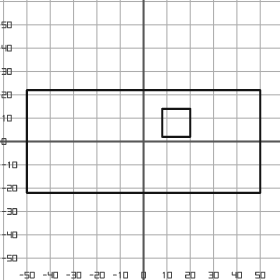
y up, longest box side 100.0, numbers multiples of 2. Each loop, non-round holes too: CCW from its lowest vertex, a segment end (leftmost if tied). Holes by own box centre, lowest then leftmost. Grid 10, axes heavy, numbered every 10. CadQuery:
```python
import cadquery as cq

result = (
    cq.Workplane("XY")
    .moveTo(-50.0, -22.0)
    .lineTo(50.0, -22.0)
    .lineTo(50.0, 22.0)
    .lineTo(-50.0, 22.0)
    .close()
    .moveTo(8.0, 2.0)
    .lineTo(20.0, 2.0)
    .lineTo(20.0, 14.0)
    .lineTo(8.0, 14.0)
    .close()
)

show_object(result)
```